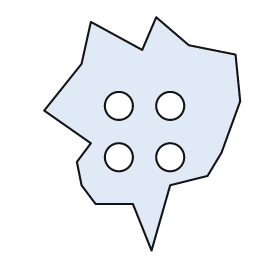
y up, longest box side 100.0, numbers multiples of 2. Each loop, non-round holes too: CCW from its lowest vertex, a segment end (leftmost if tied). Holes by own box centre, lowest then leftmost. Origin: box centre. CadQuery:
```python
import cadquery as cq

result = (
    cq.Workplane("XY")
    .moveTo(4.0, -50.0)
    .lineTo(12.0, -22.0)
    .lineTo(28.0, -18.0)
    .lineTo(34.0, -8.0)
    .lineTo(42.0, 14.0)
    .lineTo(40.0, 34.0)
    .lineTo(20.0, 38.0)
    .lineTo(6.0, 50.0)
    .lineTo(0.0, 36.0)
    .lineTo(-22.0, 48.0)
    .lineTo(-26.0, 30.0)
    .lineTo(-42.0, 10.0)
    .lineTo(-22.0, -4.0)
    .lineTo(-28.0, -12.0)
    .lineTo(-26.0, -22.0)
    .lineTo(-20.0, -30.0)
    .lineTo(-4.0, -30.0)
    .close()
    .moveTo(-10.0, -10.0)
    .circle(6.0)
    .moveTo(12.0, -10.0)
    .circle(6.0)
    .moveTo(-10.0, 12.0)
    .circle(6.0)
    .moveTo(12.0, 12.0)
    .circle(6.0)
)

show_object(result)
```